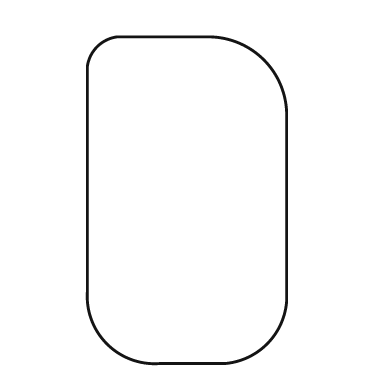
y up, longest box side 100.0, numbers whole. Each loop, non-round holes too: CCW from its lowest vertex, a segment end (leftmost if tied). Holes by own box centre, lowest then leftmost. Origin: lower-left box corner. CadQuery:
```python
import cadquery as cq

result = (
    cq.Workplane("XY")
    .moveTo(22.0, 0.0)
    .lineTo(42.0, 0.0)
    .threePointArc((55.0, 6.0), (61.0, 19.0))
    .lineTo(61.0, 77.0)
    .threePointArc((54.0, 93.0), (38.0, 100.0))
    .lineTo(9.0, 100.0)
    .threePointArc((3.0, 97.0), (0.0, 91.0))
    .lineTo(0.0, 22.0)
    .threePointArc((6.0, 6.0), (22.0, 0.0))
    .close()
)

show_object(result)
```